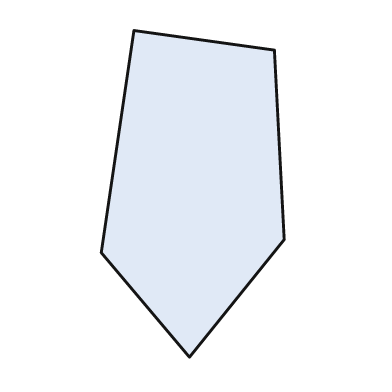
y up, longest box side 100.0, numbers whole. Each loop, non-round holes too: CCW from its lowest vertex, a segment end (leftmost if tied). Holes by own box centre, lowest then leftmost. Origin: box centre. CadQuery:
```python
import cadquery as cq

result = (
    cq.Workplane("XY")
    .moveTo(-1.0, -50.0)
    .lineTo(28.0, -14.0)
    .lineTo(25.0, 44.0)
    .lineTo(-18.0, 50.0)
    .lineTo(-28.0, -18.0)
    .close()
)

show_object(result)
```